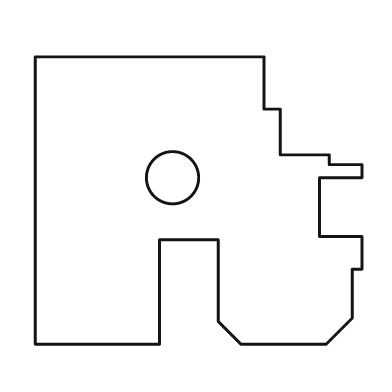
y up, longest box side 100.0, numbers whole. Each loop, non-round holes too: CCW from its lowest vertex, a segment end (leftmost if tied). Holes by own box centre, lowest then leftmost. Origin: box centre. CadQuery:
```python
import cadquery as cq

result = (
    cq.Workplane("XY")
    .moveTo(-50.0, -44.0)
    .lineTo(-12.0, -44.0)
    .lineTo(-12.0, -12.0)
    .lineTo(6.0, -12.0)
    .lineTo(6.0, -37.0)
    .lineTo(13.0, -44.0)
    .lineTo(39.0, -44.0)
    .lineTo(47.0, -36.0)
    .lineTo(47.0, -21.0)
    .lineTo(50.0, -21.0)
    .lineTo(50.0, -11.0)
    .lineTo(37.0, -11.0)
    .lineTo(37.0, 7.0)
    .lineTo(50.0, 7.0)
    .lineTo(50.0, 11.0)
    .lineTo(40.0, 11.0)
    .lineTo(40.0, 14.0)
    .lineTo(25.0, 14.0)
    .lineTo(25.0, 28.0)
    .lineTo(20.0, 28.0)
    .lineTo(20.0, 44.0)
    .lineTo(-50.0, 44.0)
    .close()
    .moveTo(-8.0, 7.0)
    .circle(8.0)
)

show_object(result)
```